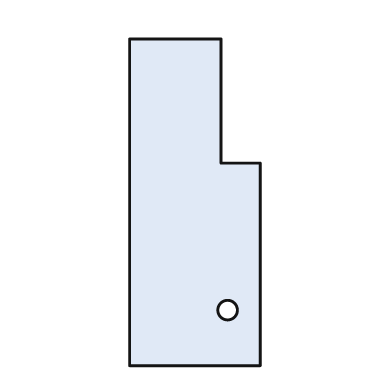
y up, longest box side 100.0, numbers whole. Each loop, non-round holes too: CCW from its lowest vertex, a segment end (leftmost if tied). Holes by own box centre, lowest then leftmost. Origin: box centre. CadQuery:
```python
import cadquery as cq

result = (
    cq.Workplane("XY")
    .moveTo(-20.0, -50.0)
    .lineTo(20.0, -50.0)
    .lineTo(20.0, 12.0)
    .lineTo(8.0, 12.0)
    .lineTo(8.0, 50.0)
    .lineTo(-20.0, 50.0)
    .close()
    .moveTo(10.0, -33.0)
    .circle(3.0)
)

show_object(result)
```